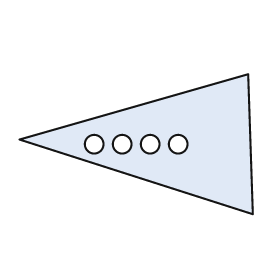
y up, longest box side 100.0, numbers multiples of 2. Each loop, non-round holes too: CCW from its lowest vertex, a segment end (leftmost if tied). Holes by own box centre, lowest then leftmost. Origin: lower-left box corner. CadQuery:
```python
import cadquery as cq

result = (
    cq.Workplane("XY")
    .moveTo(100.0, 0.0)
    .lineTo(98.0, 60.0)
    .lineTo(0.0, 32.0)
    .close()
    .moveTo(32.0, 30.0)
    .circle(4.0)
    .moveTo(44.0, 30.0)
    .circle(4.0)
    .moveTo(56.0, 30.0)
    .circle(4.0)
    .moveTo(68.0, 30.0)
    .circle(4.0)
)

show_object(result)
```